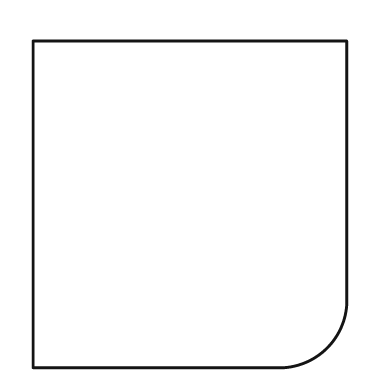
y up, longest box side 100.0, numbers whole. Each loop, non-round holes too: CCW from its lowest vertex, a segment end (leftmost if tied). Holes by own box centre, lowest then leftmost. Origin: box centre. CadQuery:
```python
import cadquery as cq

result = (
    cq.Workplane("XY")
    .moveTo(-48.0, -50.0)
    .lineTo(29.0, -50.0)
    .threePointArc((42.0, -44.0), (48.0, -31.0))
    .lineTo(48.0, 50.0)
    .lineTo(-48.0, 50.0)
    .close()
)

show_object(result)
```